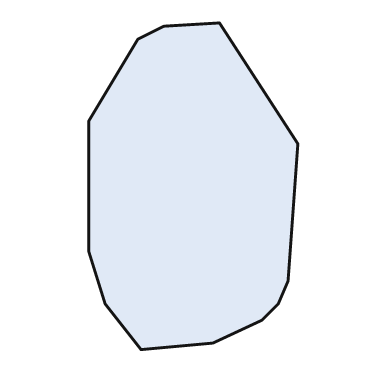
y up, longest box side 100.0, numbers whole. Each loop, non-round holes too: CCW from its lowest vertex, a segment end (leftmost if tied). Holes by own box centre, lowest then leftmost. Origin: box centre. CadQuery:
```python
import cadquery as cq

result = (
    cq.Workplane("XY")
    .moveTo(-16.0, -50.0)
    .lineTo(6.0, -48.0)
    .lineTo(21.0, -41.0)
    .lineTo(26.0, -36.0)
    .lineTo(29.0, -29.0)
    .lineTo(32.0, 13.0)
    .lineTo(8.0, 50.0)
    .lineTo(-9.0, 49.0)
    .lineTo(-17.0, 45.0)
    .lineTo(-32.0, 20.0)
    .lineTo(-32.0, -20.0)
    .lineTo(-27.0, -36.0)
    .close()
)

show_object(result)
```